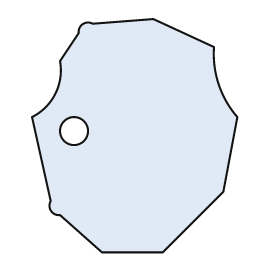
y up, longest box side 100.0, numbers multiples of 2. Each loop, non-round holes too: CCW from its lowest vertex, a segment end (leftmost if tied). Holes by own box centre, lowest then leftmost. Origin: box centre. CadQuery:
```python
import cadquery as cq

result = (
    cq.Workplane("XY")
    .moveTo(-14.0, -50.0)
    .lineTo(12.0, -50.0)
    .lineTo(38.0, -24.0)
    .lineTo(44.0, 8.0)
    .threePointArc((36.0, 22.0), (34.0, 38.0))
    .lineTo(8.0, 50.0)
    .lineTo(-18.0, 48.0)
    .threePointArc((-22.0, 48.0), (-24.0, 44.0))
    .lineTo(-32.0, 32.0)
    .threePointArc((-34.0, 18.0), (-44.0, 8.0))
    .lineTo(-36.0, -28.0)
    .threePointArc((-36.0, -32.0), (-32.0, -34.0))
    .close()
    .moveTo(-26.0, 2.0)
    .circle(6.0)
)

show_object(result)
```